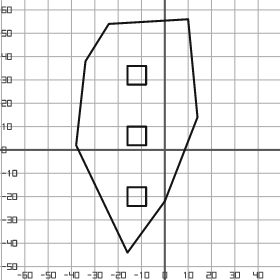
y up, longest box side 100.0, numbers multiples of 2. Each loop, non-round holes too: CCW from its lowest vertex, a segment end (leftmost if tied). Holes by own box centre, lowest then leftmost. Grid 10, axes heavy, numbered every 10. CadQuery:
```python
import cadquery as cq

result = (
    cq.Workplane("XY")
    .moveTo(-16.0, -44.0)
    .lineTo(0.0, -22.0)
    .lineTo(14.0, 14.0)
    .lineTo(10.0, 56.0)
    .lineTo(-24.0, 54.0)
    .lineTo(-34.0, 38.0)
    .lineTo(-38.0, 2.0)
    .close()
    .moveTo(-16.0, -24.0)
    .lineTo(-8.0, -24.0)
    .lineTo(-8.0, -16.0)
    .lineTo(-16.0, -16.0)
    .close()
    .moveTo(-16.0, 2.0)
    .lineTo(-8.0, 2.0)
    .lineTo(-8.0, 10.0)
    .lineTo(-16.0, 10.0)
    .close()
    .moveTo(-16.0, 28.0)
    .lineTo(-8.0, 28.0)
    .lineTo(-8.0, 36.0)
    .lineTo(-16.0, 36.0)
    .close()
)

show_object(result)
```